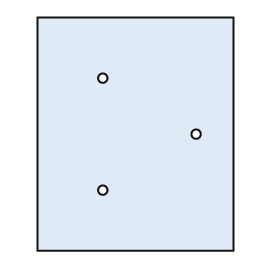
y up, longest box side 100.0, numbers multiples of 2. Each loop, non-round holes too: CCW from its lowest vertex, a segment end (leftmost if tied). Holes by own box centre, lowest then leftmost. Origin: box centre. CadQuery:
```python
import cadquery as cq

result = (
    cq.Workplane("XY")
    .moveTo(-42.0, -50.0)
    .lineTo(42.0, -50.0)
    .lineTo(42.0, 50.0)
    .lineTo(-42.0, 50.0)
    .close()
    .moveTo(-14.0, -24.0)
    .circle(2.0)
    .moveTo(26.0, 0.0)
    .circle(2.0)
    .moveTo(-14.0, 24.0)
    .circle(2.0)
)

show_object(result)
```